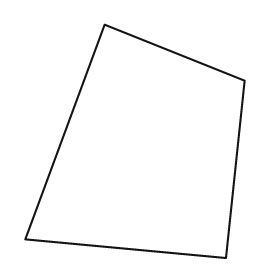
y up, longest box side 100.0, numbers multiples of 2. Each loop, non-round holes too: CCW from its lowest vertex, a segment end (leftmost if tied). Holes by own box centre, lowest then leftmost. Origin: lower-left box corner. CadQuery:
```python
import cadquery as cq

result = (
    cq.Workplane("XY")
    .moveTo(86.0, 0.0)
    .lineTo(94.0, 76.0)
    .lineTo(34.0, 100.0)
    .lineTo(0.0, 8.0)
    .close()
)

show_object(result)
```